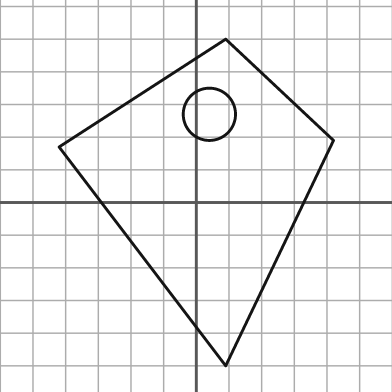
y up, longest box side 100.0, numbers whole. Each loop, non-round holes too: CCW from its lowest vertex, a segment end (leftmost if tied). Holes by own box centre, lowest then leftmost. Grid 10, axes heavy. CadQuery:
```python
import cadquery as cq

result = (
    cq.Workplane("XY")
    .moveTo(9.0, -50.0)
    .lineTo(42.0, 19.0)
    .lineTo(9.0, 50.0)
    .lineTo(-42.0, 17.0)
    .close()
    .moveTo(4.0, 27.0)
    .circle(8.0)
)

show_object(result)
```